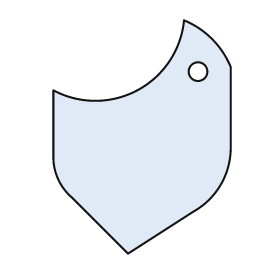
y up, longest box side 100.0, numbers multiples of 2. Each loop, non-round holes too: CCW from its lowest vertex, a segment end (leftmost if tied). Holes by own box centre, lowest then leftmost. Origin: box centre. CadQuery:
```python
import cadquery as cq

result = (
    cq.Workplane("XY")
    .moveTo(-6.0, -50.0)
    .lineTo(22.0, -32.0)
    .threePointArc((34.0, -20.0), (38.0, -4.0))
    .lineTo(38.0, 30.0)
    .threePointArc((30.0, 42.0), (18.0, 50.0))
    .threePointArc((-2.0, 20.0), (-38.0, 20.0))
    .lineTo(-38.0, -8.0)
    .threePointArc((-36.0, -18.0), (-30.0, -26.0))
    .close()
    .moveTo(24.0, 28.0)
    .circle(4.0)
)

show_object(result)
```